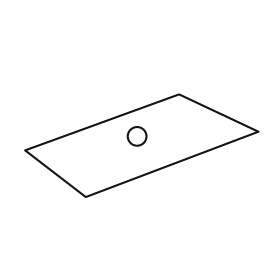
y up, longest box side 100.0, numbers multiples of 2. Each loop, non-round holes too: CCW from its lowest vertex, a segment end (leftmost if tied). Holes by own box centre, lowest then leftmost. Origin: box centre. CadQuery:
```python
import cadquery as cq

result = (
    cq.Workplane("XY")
    .moveTo(-24.0, -22.0)
    .lineTo(50.0, 6.0)
    .lineTo(16.0, 22.0)
    .lineTo(-50.0, -2.0)
    .close()
    .moveTo(-2.0, 4.0)
    .circle(4.0)
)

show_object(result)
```